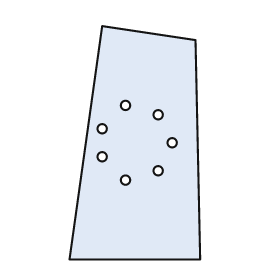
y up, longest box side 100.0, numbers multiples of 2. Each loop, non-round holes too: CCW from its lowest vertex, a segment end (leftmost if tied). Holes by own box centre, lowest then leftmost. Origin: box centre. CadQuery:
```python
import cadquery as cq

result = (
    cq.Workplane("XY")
    .moveTo(-28.0, -50.0)
    .lineTo(28.0, -50.0)
    .lineTo(26.0, 44.0)
    .lineTo(-14.0, 50.0)
    .close()
    .moveTo(-4.0, -16.0)
    .circle(2.0)
    .moveTo(10.0, -12.0)
    .circle(2.0)
    .moveTo(-14.0, -6.0)
    .circle(2.0)
    .moveTo(16.0, 0.0)
    .circle(2.0)
    .moveTo(-14.0, 6.0)
    .circle(2.0)
    .moveTo(10.0, 12.0)
    .circle(2.0)
    .moveTo(-4.0, 16.0)
    .circle(2.0)
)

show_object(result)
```